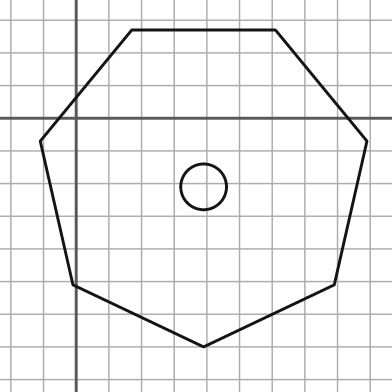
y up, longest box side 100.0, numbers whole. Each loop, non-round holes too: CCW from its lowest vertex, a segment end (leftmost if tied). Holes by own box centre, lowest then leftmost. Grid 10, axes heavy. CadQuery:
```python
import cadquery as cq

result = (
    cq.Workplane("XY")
    .moveTo(39.0, -70.0)
    .lineTo(79.0, -51.0)
    .lineTo(89.0, -7.0)
    .lineTo(61.0, 27.0)
    .lineTo(17.0, 27.0)
    .lineTo(-11.0, -7.0)
    .lineTo(-1.0, -51.0)
    .close()
    .moveTo(39.0, -21.0)
    .circle(7.0)
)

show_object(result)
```